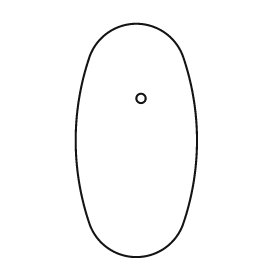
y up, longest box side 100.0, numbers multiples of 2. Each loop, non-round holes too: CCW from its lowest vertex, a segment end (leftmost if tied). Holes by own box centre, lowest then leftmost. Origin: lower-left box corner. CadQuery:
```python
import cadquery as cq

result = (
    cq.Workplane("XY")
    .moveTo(6.0, 14.0)
    .threePointArc((26.0, 0.0), (46.0, 14.0))
    .threePointArc((52.0, 50.0), (46.0, 86.0))
    .threePointArc((26.0, 100.0), (6.0, 86.0))
    .threePointArc((0.0, 50.0), (6.0, 14.0))
    .close()
    .moveTo(28.0, 68.0)
    .circle(2.0)
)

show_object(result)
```